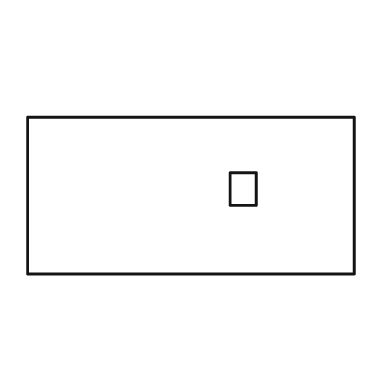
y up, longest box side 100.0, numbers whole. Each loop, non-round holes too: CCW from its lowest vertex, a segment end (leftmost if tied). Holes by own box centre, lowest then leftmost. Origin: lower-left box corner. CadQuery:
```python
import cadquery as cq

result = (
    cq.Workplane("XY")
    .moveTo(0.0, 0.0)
    .lineTo(100.0, 0.0)
    .lineTo(100.0, 48.0)
    .lineTo(0.0, 48.0)
    .close()
    .moveTo(62.0, 21.0)
    .lineTo(70.0, 21.0)
    .lineTo(70.0, 31.0)
    .lineTo(62.0, 31.0)
    .close()
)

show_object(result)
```